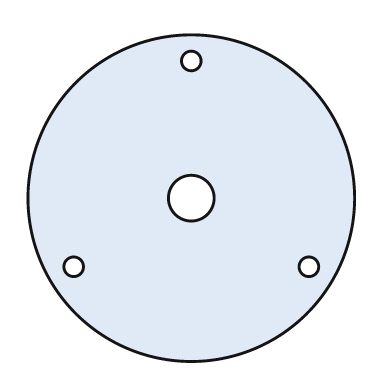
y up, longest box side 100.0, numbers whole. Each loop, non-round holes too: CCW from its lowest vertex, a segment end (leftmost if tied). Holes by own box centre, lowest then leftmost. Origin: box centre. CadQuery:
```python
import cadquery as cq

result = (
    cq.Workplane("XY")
    .moveTo(0.0, 0.0)
    .circle(50.0)
    .moveTo(-36.0, -21.0)
    .circle(3.0)
    .moveTo(36.0, -21.0)
    .circle(3.0)
    .moveTo(0.0, 0.0)
    .circle(7.0)
    .moveTo(0.0, 42.0)
    .circle(3.0)
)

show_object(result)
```